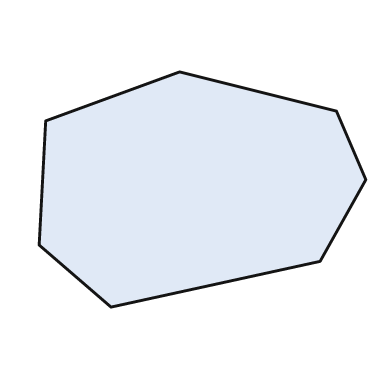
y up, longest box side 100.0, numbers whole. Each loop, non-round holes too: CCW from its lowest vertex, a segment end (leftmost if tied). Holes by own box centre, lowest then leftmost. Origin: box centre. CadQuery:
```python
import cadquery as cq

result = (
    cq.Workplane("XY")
    .moveTo(-28.0, -36.0)
    .lineTo(36.0, -22.0)
    .lineTo(50.0, 3.0)
    .lineTo(41.0, 24.0)
    .lineTo(-7.0, 36.0)
    .lineTo(-48.0, 21.0)
    .lineTo(-50.0, -17.0)
    .close()
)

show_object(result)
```